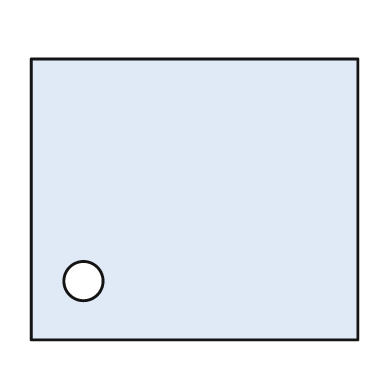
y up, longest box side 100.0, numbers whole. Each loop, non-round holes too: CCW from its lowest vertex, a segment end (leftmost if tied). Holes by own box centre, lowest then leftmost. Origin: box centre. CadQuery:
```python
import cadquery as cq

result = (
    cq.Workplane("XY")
    .moveTo(-50.0, -43.0)
    .lineTo(50.0, -43.0)
    .lineTo(50.0, 43.0)
    .lineTo(-50.0, 43.0)
    .close()
    .moveTo(-34.0, -25.0)
    .circle(6.0)
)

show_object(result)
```